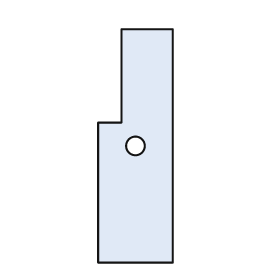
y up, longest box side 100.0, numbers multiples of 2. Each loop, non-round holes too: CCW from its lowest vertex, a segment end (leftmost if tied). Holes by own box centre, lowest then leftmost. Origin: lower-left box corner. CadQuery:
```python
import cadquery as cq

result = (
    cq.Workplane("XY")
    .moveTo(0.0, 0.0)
    .lineTo(32.0, 0.0)
    .lineTo(32.0, 100.0)
    .lineTo(10.0, 100.0)
    .lineTo(10.0, 60.0)
    .lineTo(0.0, 60.0)
    .close()
    .moveTo(16.0, 50.0)
    .circle(4.0)
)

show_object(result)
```